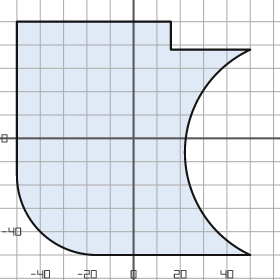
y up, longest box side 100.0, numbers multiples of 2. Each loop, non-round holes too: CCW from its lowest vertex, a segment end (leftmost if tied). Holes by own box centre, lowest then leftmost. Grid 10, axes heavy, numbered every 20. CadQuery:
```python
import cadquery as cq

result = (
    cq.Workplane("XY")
    .moveTo(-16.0, -50.0)
    .lineTo(50.0, -50.0)
    .threePointArc((22.0, -6.0), (50.0, 38.0))
    .lineTo(16.0, 38.0)
    .lineTo(16.0, 50.0)
    .lineTo(-50.0, 50.0)
    .lineTo(-50.0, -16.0)
    .threePointArc((-40.0, -40.0), (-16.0, -50.0))
    .close()
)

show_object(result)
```